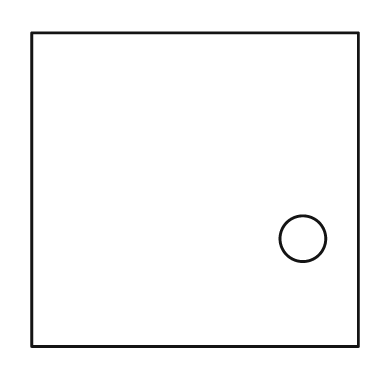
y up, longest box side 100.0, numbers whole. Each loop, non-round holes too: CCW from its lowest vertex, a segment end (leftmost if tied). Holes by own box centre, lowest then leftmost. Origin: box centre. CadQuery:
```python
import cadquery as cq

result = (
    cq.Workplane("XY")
    .moveTo(-50.0, -48.0)
    .lineTo(50.0, -48.0)
    .lineTo(50.0, 48.0)
    .lineTo(-50.0, 48.0)
    .close()
    .moveTo(33.0, -15.0)
    .circle(7.0)
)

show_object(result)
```